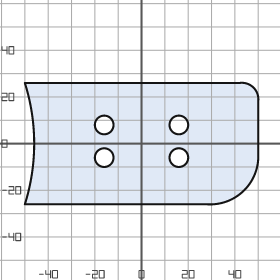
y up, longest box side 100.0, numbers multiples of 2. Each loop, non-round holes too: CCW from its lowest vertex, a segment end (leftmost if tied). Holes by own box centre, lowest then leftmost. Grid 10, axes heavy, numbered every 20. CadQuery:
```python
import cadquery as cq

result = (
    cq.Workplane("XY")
    .moveTo(-50.0, -26.0)
    .lineTo(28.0, -26.0)
    .threePointArc((44.0, -20.0), (50.0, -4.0))
    .lineTo(50.0, 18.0)
    .threePointArc((48.0, 24.0), (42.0, 26.0))
    .lineTo(-50.0, 26.0)
    .threePointArc((-46.0, 0.0), (-50.0, -26.0))
    .close()
    .moveTo(-16.0, -6.0)
    .circle(4.0)
    .moveTo(16.0, -6.0)
    .circle(4.0)
    .moveTo(-16.0, 8.0)
    .circle(4.0)
    .moveTo(16.0, 8.0)
    .circle(4.0)
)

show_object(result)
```